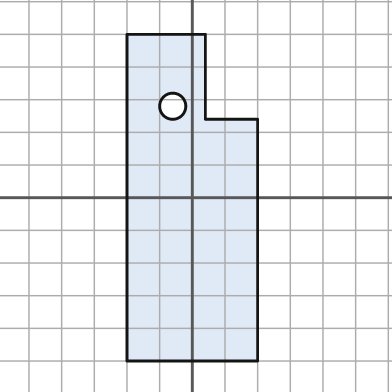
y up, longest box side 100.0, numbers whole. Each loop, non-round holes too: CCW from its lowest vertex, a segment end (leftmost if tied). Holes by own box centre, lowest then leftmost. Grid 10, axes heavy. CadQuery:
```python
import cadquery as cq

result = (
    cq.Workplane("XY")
    .moveTo(-20.0, -50.0)
    .lineTo(20.0, -50.0)
    .lineTo(20.0, 24.0)
    .lineTo(4.0, 24.0)
    .lineTo(4.0, 50.0)
    .lineTo(-20.0, 50.0)
    .close()
    .moveTo(-6.0, 28.0)
    .circle(4.0)
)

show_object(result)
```